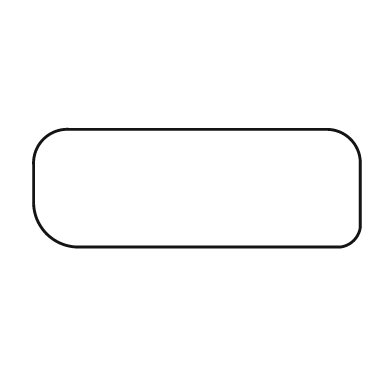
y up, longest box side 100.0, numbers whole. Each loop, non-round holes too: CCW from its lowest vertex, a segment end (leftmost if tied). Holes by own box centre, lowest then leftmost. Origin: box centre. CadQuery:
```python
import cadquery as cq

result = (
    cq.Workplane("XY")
    .moveTo(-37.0, -18.0)
    .lineTo(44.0, -18.0)
    .threePointArc((48.0, -16.0), (50.0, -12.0))
    .lineTo(50.0, 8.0)
    .threePointArc((47.0, 15.0), (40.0, 18.0))
    .lineTo(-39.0, 18.0)
    .threePointArc((-47.0, 15.0), (-50.0, 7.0))
    .lineTo(-50.0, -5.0)
    .threePointArc((-46.0, -14.0), (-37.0, -18.0))
    .close()
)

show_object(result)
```